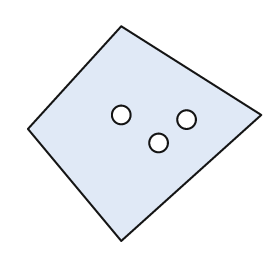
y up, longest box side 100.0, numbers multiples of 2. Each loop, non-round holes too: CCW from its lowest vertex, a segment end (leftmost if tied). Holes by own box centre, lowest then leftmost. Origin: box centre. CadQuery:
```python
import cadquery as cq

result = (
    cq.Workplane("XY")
    .moveTo(-10.0, -46.0)
    .lineTo(50.0, 8.0)
    .lineTo(-10.0, 46.0)
    .lineTo(-50.0, 2.0)
    .close()
    .moveTo(6.0, -4.0)
    .circle(4.0)
    .moveTo(18.0, 6.0)
    .circle(4.0)
    .moveTo(-10.0, 8.0)
    .circle(4.0)
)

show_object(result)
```